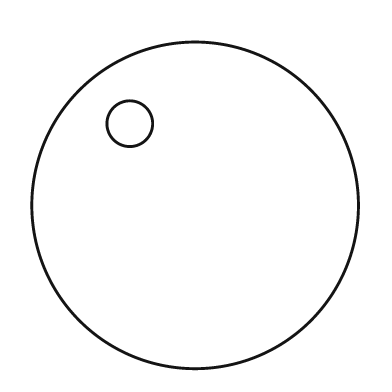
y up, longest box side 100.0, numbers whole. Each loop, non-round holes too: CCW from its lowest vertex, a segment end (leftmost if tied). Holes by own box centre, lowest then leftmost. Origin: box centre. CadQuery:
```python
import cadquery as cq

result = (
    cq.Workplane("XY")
    .moveTo(0.0, 0.0)
    .circle(50.0)
    .moveTo(-20.0, 25.0)
    .circle(7.0)
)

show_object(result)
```